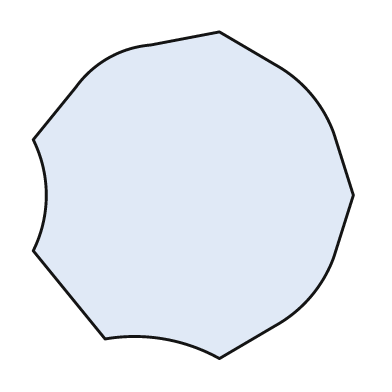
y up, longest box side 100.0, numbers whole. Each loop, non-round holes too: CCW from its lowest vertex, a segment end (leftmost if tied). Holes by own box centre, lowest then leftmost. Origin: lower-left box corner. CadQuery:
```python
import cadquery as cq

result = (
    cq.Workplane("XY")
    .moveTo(57.0, 0.0)
    .lineTo(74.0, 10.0)
    .threePointArc((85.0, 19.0), (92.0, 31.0))
    .lineTo(98.0, 50.0)
    .lineTo(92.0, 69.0)
    .threePointArc((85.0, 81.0), (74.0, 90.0))
    .lineTo(57.0, 100.0)
    .lineTo(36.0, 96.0)
    .threePointArc((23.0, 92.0), (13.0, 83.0))
    .lineTo(0.0, 67.0)
    .threePointArc((4.0, 50.0), (0.0, 33.0))
    .lineTo(22.0, 6.0)
    .threePointArc((40.0, 6.0), (57.0, 0.0))
    .close()
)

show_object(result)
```